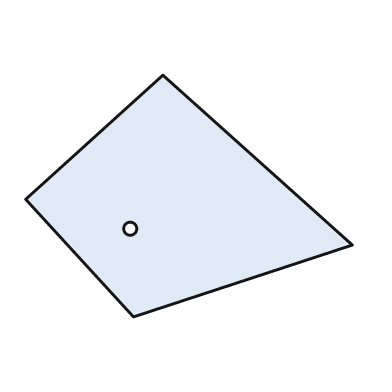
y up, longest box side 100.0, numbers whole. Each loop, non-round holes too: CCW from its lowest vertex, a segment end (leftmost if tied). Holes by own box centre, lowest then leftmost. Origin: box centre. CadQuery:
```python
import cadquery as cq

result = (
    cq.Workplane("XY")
    .moveTo(-17.0, -37.0)
    .lineTo(50.0, -15.0)
    .lineTo(-8.0, 37.0)
    .lineTo(-50.0, -1.0)
    .close()
    .moveTo(-18.0, -10.0)
    .circle(2.0)
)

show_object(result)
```